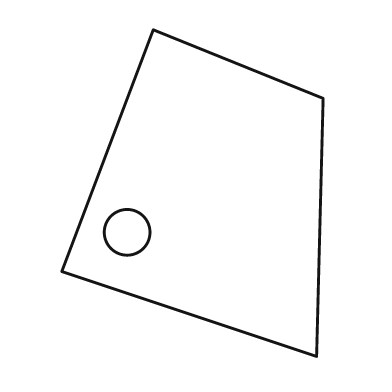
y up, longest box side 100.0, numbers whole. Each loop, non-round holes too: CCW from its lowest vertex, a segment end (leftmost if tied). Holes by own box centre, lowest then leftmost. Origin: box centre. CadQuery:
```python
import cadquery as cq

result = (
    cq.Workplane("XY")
    .moveTo(38.0, -50.0)
    .lineTo(40.0, 29.0)
    .lineTo(-12.0, 50.0)
    .lineTo(-40.0, -24.0)
    .close()
    .moveTo(-20.0, -12.0)
    .circle(7.0)
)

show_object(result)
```